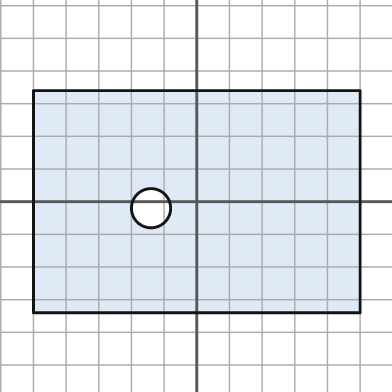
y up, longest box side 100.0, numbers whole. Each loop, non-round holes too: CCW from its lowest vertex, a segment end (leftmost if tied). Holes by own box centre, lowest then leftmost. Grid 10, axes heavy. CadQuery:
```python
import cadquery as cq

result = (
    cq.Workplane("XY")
    .moveTo(-50.0, -34.0)
    .lineTo(50.0, -34.0)
    .lineTo(50.0, 34.0)
    .lineTo(-50.0, 34.0)
    .close()
    .moveTo(-14.0, -2.0)
    .circle(6.0)
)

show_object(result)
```